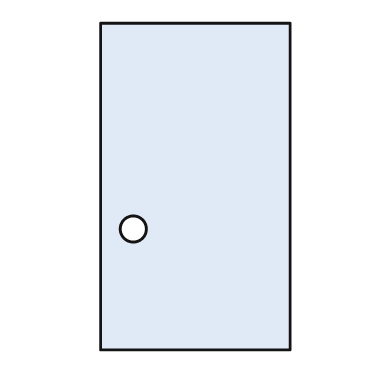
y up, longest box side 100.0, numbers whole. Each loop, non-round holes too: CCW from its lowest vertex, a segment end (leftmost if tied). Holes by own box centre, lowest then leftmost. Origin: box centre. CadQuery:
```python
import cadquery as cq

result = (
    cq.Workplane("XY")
    .moveTo(-29.0, -50.0)
    .lineTo(29.0, -50.0)
    .lineTo(29.0, 50.0)
    .lineTo(-29.0, 50.0)
    .close()
    .moveTo(-19.0, -13.0)
    .circle(4.0)
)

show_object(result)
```